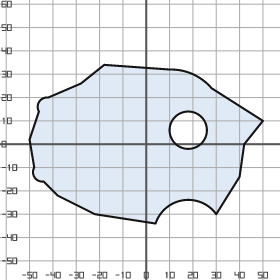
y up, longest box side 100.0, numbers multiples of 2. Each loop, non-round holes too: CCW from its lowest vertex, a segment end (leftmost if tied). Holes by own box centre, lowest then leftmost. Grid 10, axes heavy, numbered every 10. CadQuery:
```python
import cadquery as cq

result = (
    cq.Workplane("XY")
    .moveTo(4.0, -34.0)
    .threePointArc((16.0, -24.0), (30.0, -30.0))
    .lineTo(40.0, -14.0)
    .lineTo(42.0, 0.0)
    .lineTo(50.0, 10.0)
    .lineTo(28.0, 24.0)
    .threePointArc((20.0, 30.0), (10.0, 32.0))
    .lineTo(-18.0, 34.0)
    .lineTo(-28.0, 26.0)
    .lineTo(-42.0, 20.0)
    .threePointArc((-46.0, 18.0), (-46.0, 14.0))
    .lineTo(-50.0, 2.0)
    .lineTo(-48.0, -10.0)
    .threePointArc((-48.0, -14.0), (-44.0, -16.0))
    .lineTo(-38.0, -22.0)
    .lineTo(-22.0, -30.0)
    .close()
    .moveTo(18.0, 6.0)
    .circle(8.0)
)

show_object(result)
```